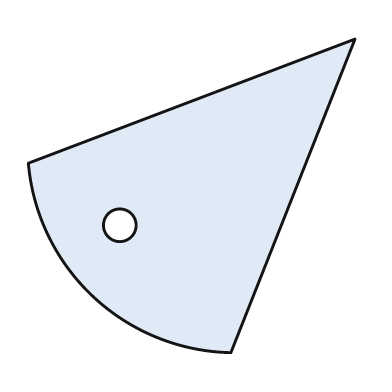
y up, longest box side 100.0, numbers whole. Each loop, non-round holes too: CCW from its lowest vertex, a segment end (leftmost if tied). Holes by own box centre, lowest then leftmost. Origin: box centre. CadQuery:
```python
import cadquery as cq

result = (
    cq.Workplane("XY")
    .moveTo(12.0, -48.0)
    .lineTo(50.0, 48.0)
    .lineTo(-50.0, 10.0)
    .threePointArc((-30.0, -31.0), (12.0, -48.0))
    .close()
    .moveTo(-22.0, -9.0)
    .circle(5.0)
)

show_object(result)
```